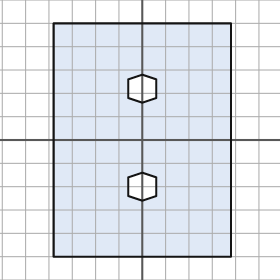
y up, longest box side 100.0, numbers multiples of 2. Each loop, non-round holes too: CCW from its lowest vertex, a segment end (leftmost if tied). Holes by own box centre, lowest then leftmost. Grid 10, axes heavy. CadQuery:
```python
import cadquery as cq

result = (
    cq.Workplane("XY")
    .moveTo(-38.0, -50.0)
    .lineTo(38.0, -50.0)
    .lineTo(38.0, 50.0)
    .lineTo(-38.0, 50.0)
    .close()
    .moveTo(0.0, -26.0)
    .lineTo(6.0, -24.0)
    .lineTo(6.0, -16.0)
    .lineTo(0.0, -14.0)
    .lineTo(-6.0, -16.0)
    .lineTo(-6.0, -24.0)
    .close()
    .moveTo(0.0, 16.0)
    .lineTo(6.0, 18.0)
    .lineTo(6.0, 26.0)
    .lineTo(0.0, 28.0)
    .lineTo(-6.0, 26.0)
    .lineTo(-6.0, 18.0)
    .close()
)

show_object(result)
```